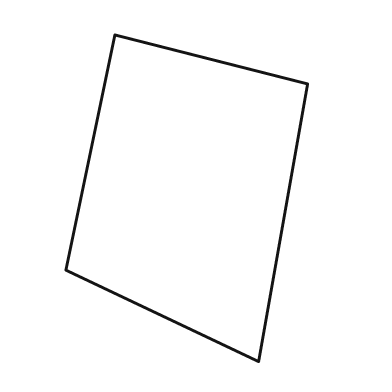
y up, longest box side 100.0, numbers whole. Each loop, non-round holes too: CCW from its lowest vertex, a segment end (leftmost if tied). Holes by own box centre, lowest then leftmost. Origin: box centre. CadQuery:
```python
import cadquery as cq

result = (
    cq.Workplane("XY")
    .moveTo(22.0, -50.0)
    .lineTo(37.0, 35.0)
    .lineTo(-22.0, 50.0)
    .lineTo(-37.0, -22.0)
    .close()
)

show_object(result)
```